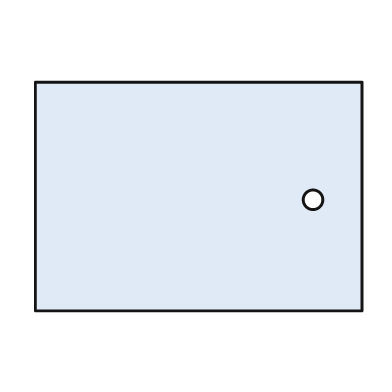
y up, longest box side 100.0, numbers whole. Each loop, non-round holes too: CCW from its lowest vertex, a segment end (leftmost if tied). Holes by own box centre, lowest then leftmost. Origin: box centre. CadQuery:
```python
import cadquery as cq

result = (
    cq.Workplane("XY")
    .moveTo(-50.0, -35.0)
    .lineTo(50.0, -35.0)
    .lineTo(50.0, 35.0)
    .lineTo(-50.0, 35.0)
    .close()
    .moveTo(35.0, -1.0)
    .circle(3.0)
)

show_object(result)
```